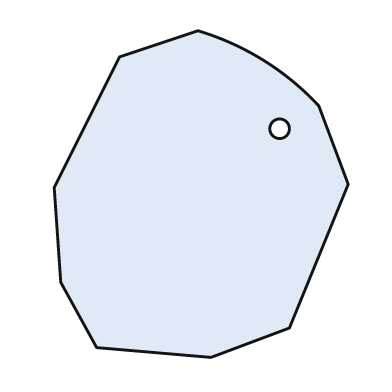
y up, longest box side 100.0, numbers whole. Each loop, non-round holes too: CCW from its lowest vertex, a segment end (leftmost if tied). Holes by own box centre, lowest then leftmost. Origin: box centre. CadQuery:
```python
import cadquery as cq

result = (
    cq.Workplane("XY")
    .moveTo(3.0, -50.0)
    .lineTo(27.0, -41.0)
    .lineTo(45.0, 3.0)
    .lineTo(36.0, 27.0)
    .threePointArc((19.0, 41.0), (-1.0, 50.0))
    .lineTo(-25.0, 42.0)
    .lineTo(-45.0, 2.0)
    .lineTo(-43.0, -27.0)
    .lineTo(-32.0, -47.0)
    .close()
    .moveTo(24.0, 20.0)
    .circle(3.0)
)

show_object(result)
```